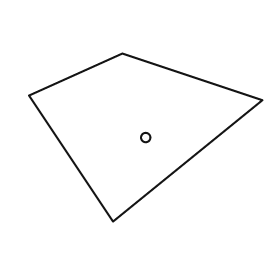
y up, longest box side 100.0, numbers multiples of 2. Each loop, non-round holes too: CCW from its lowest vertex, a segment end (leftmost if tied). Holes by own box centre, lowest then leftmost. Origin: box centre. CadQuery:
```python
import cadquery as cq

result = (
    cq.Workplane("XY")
    .moveTo(-14.0, -36.0)
    .lineTo(50.0, 16.0)
    .lineTo(-10.0, 36.0)
    .lineTo(-50.0, 18.0)
    .close()
    .moveTo(0.0, 0.0)
    .circle(2.0)
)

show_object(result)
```